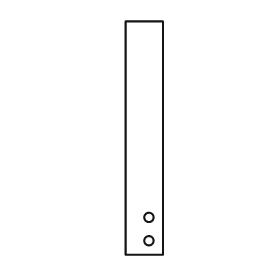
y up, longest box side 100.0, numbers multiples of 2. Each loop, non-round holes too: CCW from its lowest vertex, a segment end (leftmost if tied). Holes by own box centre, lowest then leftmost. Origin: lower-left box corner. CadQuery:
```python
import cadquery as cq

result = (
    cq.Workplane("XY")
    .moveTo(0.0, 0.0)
    .lineTo(16.0, 0.0)
    .lineTo(16.0, 100.0)
    .lineTo(0.0, 100.0)
    .close()
    .moveTo(10.0, 6.0)
    .circle(2.0)
    .moveTo(10.0, 16.0)
    .circle(2.0)
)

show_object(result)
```